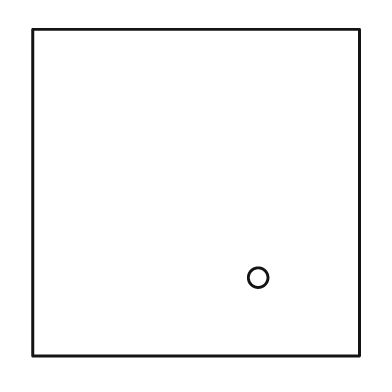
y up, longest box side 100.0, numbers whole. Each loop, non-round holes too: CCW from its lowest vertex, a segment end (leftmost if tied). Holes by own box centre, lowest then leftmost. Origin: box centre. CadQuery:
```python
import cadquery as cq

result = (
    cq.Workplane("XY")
    .moveTo(-50.0, -50.0)
    .lineTo(50.0, -50.0)
    .lineTo(50.0, 50.0)
    .lineTo(-50.0, 50.0)
    .close()
    .moveTo(19.0, -26.0)
    .circle(3.0)
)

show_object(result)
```